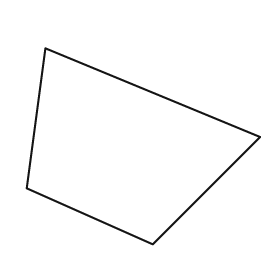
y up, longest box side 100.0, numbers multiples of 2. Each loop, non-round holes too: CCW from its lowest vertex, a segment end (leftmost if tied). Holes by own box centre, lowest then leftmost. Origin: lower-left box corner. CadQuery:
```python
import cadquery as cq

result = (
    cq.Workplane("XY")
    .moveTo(54.0, 0.0)
    .lineTo(100.0, 46.0)
    .lineTo(8.0, 84.0)
    .lineTo(0.0, 24.0)
    .close()
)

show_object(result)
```